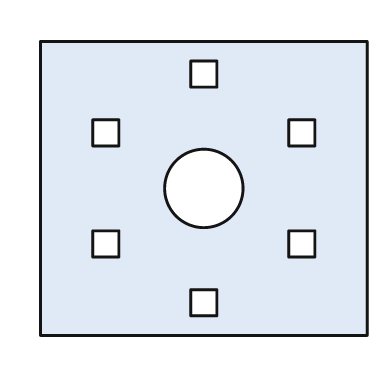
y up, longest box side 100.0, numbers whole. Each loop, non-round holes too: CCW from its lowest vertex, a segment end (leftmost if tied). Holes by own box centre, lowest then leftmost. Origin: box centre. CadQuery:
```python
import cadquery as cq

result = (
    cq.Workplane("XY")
    .moveTo(-50.0, -45.0)
    .lineTo(50.0, -45.0)
    .lineTo(50.0, 45.0)
    .lineTo(-50.0, 45.0)
    .close()
    .moveTo(-4.0, -39.0)
    .lineTo(4.0, -39.0)
    .lineTo(4.0, -31.0)
    .lineTo(-4.0, -31.0)
    .close()
    .moveTo(-34.0, -21.0)
    .lineTo(-26.0, -21.0)
    .lineTo(-26.0, -13.0)
    .lineTo(-34.0, -13.0)
    .close()
    .moveTo(26.0, -21.0)
    .lineTo(34.0, -21.0)
    .lineTo(34.0, -13.0)
    .lineTo(26.0, -13.0)
    .close()
    .moveTo(0.0, 0.0)
    .circle(12.0)
    .moveTo(-34.0, 13.0)
    .lineTo(-26.0, 13.0)
    .lineTo(-26.0, 21.0)
    .lineTo(-34.0, 21.0)
    .close()
    .moveTo(26.0, 13.0)
    .lineTo(34.0, 13.0)
    .lineTo(34.0, 21.0)
    .lineTo(26.0, 21.0)
    .close()
    .moveTo(-4.0, 31.0)
    .lineTo(4.0, 31.0)
    .lineTo(4.0, 39.0)
    .lineTo(-4.0, 39.0)
    .close()
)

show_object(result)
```